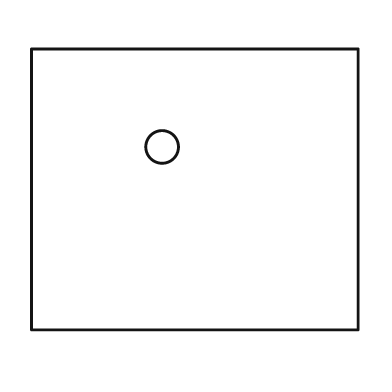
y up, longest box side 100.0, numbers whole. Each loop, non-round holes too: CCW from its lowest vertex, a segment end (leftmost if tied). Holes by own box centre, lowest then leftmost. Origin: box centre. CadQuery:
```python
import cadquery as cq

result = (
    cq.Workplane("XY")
    .moveTo(-50.0, -43.0)
    .lineTo(50.0, -43.0)
    .lineTo(50.0, 43.0)
    .lineTo(-50.0, 43.0)
    .close()
    .moveTo(-10.0, 13.0)
    .circle(5.0)
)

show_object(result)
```